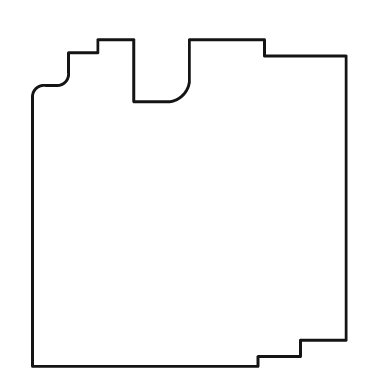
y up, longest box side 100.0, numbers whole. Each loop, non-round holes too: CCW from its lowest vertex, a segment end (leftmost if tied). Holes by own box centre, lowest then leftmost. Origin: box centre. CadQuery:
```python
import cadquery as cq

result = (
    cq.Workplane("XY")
    .moveTo(-48.0, -50.0)
    .lineTo(21.0, -50.0)
    .lineTo(21.0, -47.0)
    .lineTo(34.0, -47.0)
    .lineTo(34.0, -42.0)
    .lineTo(48.0, -42.0)
    .lineTo(48.0, 45.0)
    .lineTo(23.0, 45.0)
    .lineTo(23.0, 50.0)
    .lineTo(0.0, 50.0)
    .lineTo(0.0, 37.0)
    .threePointArc((-2.0, 33.0), (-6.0, 31.0))
    .lineTo(-17.0, 31.0)
    .lineTo(-17.0, 50.0)
    .lineTo(-28.0, 50.0)
    .lineTo(-28.0, 46.0)
    .lineTo(-37.0, 46.0)
    .lineTo(-37.0, 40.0)
    .threePointArc((-38.0, 37.0), (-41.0, 36.0))
    .lineTo(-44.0, 36.0)
    .threePointArc((-47.0, 35.0), (-48.0, 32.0))
    .close()
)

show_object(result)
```